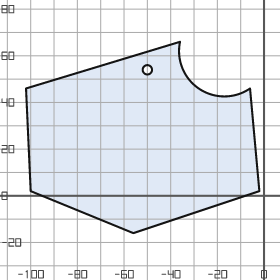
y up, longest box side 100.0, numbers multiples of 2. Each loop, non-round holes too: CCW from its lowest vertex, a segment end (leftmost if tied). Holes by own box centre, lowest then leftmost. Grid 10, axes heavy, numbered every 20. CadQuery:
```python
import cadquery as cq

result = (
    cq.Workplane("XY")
    .moveTo(-56.0, -16.0)
    .lineTo(-2.0, 2.0)
    .lineTo(-6.0, 46.0)
    .threePointArc((-28.0, 46.0), (-36.0, 66.0))
    .lineTo(-102.0, 46.0)
    .lineTo(-100.0, 2.0)
    .close()
    .moveTo(-50.0, 54.0)
    .circle(2.0)
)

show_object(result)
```